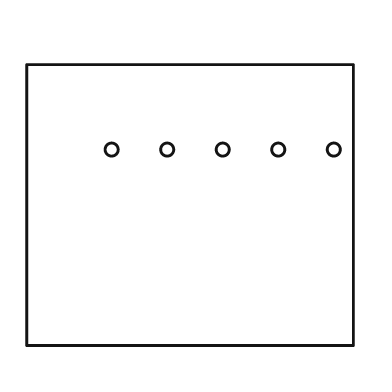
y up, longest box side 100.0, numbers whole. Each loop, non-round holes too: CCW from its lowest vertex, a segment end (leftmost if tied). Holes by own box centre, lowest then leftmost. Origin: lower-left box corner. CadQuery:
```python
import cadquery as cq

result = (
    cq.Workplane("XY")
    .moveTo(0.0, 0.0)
    .lineTo(100.0, 0.0)
    .lineTo(100.0, 86.0)
    .lineTo(0.0, 86.0)
    .close()
    .moveTo(26.0, 60.0)
    .circle(2.0)
    .moveTo(43.0, 60.0)
    .circle(2.0)
    .moveTo(60.0, 60.0)
    .circle(2.0)
    .moveTo(77.0, 60.0)
    .circle(2.0)
    .moveTo(94.0, 60.0)
    .circle(2.0)
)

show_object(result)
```